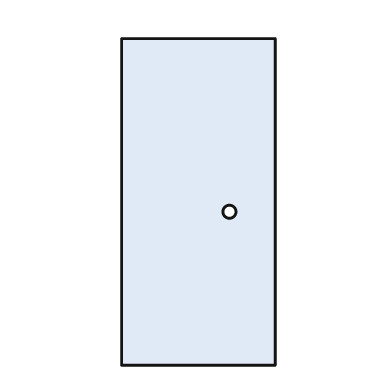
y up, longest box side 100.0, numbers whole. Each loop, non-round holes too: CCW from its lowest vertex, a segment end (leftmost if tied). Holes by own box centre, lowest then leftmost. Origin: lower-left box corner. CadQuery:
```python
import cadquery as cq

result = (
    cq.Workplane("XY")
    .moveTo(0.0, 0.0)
    .lineTo(47.0, 0.0)
    .lineTo(47.0, 100.0)
    .lineTo(0.0, 100.0)
    .close()
    .moveTo(33.0, 47.0)
    .circle(2.0)
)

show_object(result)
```